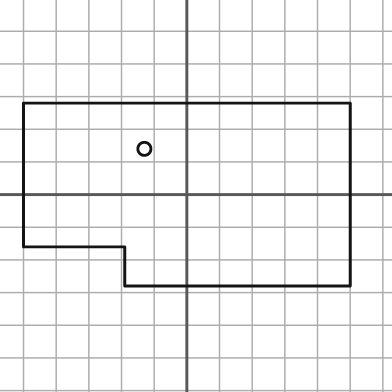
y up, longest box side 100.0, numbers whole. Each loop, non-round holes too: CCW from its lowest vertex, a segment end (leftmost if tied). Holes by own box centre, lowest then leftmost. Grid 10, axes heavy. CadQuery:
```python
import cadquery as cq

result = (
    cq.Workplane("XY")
    .moveTo(-19.0, -28.0)
    .lineTo(50.0, -28.0)
    .lineTo(50.0, 28.0)
    .lineTo(-50.0, 28.0)
    .lineTo(-50.0, -16.0)
    .lineTo(-19.0, -16.0)
    .close()
    .moveTo(-13.0, 14.0)
    .circle(2.0)
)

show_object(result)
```